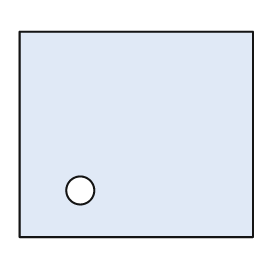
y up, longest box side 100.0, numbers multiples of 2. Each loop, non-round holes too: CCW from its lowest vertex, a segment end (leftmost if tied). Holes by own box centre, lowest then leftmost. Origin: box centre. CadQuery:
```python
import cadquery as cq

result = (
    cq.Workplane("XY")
    .moveTo(-50.0, -44.0)
    .lineTo(50.0, -44.0)
    .lineTo(50.0, 44.0)
    .lineTo(-50.0, 44.0)
    .close()
    .moveTo(-24.0, -24.0)
    .circle(6.0)
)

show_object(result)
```